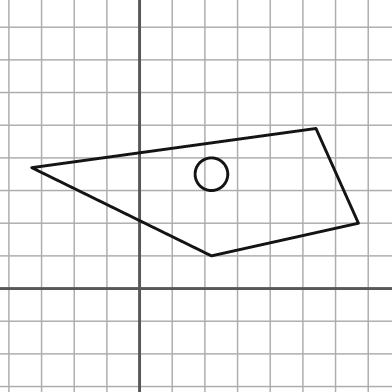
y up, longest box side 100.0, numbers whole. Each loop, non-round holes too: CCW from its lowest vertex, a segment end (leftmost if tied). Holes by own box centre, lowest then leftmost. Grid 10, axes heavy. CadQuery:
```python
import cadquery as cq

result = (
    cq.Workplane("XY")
    .moveTo(22.0, 10.0)
    .lineTo(67.0, 20.0)
    .lineTo(54.0, 49.0)
    .lineTo(-33.0, 37.0)
    .close()
    .moveTo(22.0, 35.0)
    .circle(5.0)
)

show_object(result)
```